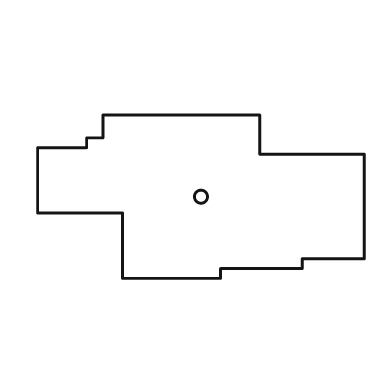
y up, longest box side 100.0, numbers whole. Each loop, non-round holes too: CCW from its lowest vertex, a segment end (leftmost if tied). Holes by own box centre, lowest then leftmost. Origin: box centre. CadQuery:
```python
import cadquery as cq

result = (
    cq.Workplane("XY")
    .moveTo(-24.0, -25.0)
    .lineTo(6.0, -25.0)
    .lineTo(6.0, -22.0)
    .lineTo(31.0, -22.0)
    .lineTo(31.0, -19.0)
    .lineTo(50.0, -19.0)
    .lineTo(50.0, 13.0)
    .lineTo(18.0, 13.0)
    .lineTo(18.0, 25.0)
    .lineTo(-30.0, 25.0)
    .lineTo(-30.0, 18.0)
    .lineTo(-35.0, 18.0)
    .lineTo(-35.0, 15.0)
    .lineTo(-50.0, 15.0)
    .lineTo(-50.0, -5.0)
    .lineTo(-24.0, -5.0)
    .close()
    .moveTo(0.0, 0.0)
    .circle(2.0)
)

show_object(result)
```